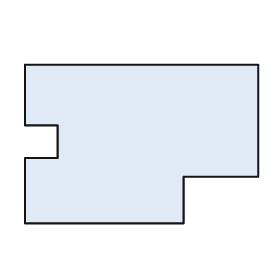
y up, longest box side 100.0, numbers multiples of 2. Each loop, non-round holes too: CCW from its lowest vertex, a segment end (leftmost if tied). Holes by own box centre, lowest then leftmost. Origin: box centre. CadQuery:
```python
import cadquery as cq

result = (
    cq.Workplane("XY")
    .moveTo(-50.0, -34.0)
    .lineTo(18.0, -34.0)
    .lineTo(18.0, -14.0)
    .lineTo(50.0, -14.0)
    .lineTo(50.0, 34.0)
    .lineTo(-50.0, 34.0)
    .lineTo(-50.0, 8.0)
    .lineTo(-36.0, 8.0)
    .lineTo(-36.0, -6.0)
    .lineTo(-50.0, -6.0)
    .close()
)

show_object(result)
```